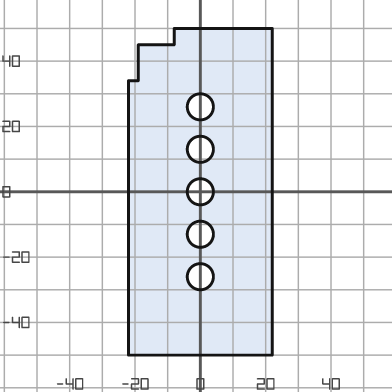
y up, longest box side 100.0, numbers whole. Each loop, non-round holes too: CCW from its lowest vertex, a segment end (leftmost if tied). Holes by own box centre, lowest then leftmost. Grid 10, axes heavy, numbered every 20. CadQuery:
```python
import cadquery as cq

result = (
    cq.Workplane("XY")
    .moveTo(-22.0, -50.0)
    .lineTo(22.0, -50.0)
    .lineTo(22.0, 50.0)
    .lineTo(-8.0, 50.0)
    .lineTo(-8.0, 45.0)
    .lineTo(-19.0, 45.0)
    .lineTo(-19.0, 34.0)
    .lineTo(-22.0, 34.0)
    .close()
    .moveTo(0.0, -26.0)
    .circle(4.0)
    .moveTo(0.0, -13.0)
    .circle(4.0)
    .moveTo(0.0, 0.0)
    .circle(4.0)
    .moveTo(0.0, 13.0)
    .circle(4.0)
    .moveTo(0.0, 26.0)
    .circle(4.0)
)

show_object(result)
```